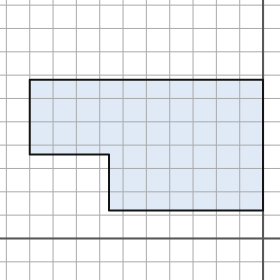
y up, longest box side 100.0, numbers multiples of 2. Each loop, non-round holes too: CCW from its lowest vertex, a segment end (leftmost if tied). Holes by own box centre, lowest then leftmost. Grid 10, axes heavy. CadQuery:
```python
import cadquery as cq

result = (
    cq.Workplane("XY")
    .moveTo(-66.0, 12.0)
    .lineTo(0.0, 12.0)
    .lineTo(0.0, 68.0)
    .lineTo(-100.0, 68.0)
    .lineTo(-100.0, 36.0)
    .lineTo(-66.0, 36.0)
    .close()
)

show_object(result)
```